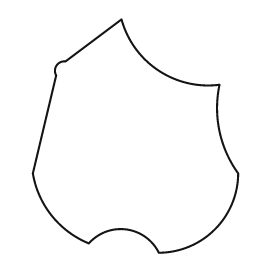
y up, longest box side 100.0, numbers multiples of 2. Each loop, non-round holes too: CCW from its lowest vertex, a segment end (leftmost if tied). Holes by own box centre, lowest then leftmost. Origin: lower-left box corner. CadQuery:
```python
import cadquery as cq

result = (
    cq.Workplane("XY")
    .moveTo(54.0, 0.0)
    .threePointArc((78.0, 10.0), (88.0, 34.0))
    .threePointArc((80.0, 52.0), (80.0, 72.0))
    .threePointArc((54.0, 78.0), (38.0, 100.0))
    .lineTo(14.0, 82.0)
    .threePointArc((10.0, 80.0), (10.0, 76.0))
    .lineTo(0.0, 34.0)
    .threePointArc((8.0, 16.0), (24.0, 4.0))
    .threePointArc((40.0, 10.0), (54.0, 0.0))
    .close()
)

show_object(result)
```